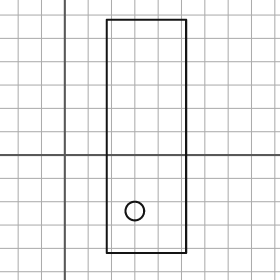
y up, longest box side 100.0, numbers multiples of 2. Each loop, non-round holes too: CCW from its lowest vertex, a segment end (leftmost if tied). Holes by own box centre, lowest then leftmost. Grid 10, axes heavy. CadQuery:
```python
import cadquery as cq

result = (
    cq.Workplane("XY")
    .moveTo(18.0, -42.0)
    .lineTo(52.0, -42.0)
    .lineTo(52.0, 58.0)
    .lineTo(18.0, 58.0)
    .close()
    .moveTo(30.0, -24.0)
    .circle(4.0)
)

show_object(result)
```